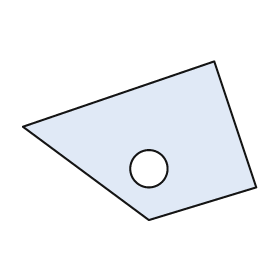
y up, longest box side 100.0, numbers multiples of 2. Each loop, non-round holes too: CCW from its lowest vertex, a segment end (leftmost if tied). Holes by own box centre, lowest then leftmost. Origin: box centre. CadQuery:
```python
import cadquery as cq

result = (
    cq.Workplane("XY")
    .moveTo(4.0, -34.0)
    .lineTo(50.0, -20.0)
    .lineTo(32.0, 34.0)
    .lineTo(-50.0, 6.0)
    .close()
    .moveTo(4.0, -12.0)
    .circle(8.0)
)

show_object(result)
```